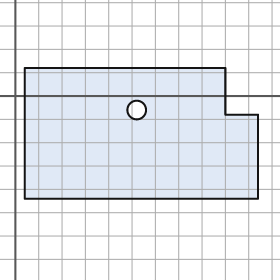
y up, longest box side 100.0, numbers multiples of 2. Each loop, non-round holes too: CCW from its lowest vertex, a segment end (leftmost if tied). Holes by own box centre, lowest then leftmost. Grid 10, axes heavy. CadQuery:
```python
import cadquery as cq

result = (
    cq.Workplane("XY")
    .moveTo(4.0, -44.0)
    .lineTo(104.0, -44.0)
    .lineTo(104.0, -8.0)
    .lineTo(90.0, -8.0)
    .lineTo(90.0, 12.0)
    .lineTo(4.0, 12.0)
    .close()
    .moveTo(52.0, -6.0)
    .circle(4.0)
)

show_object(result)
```